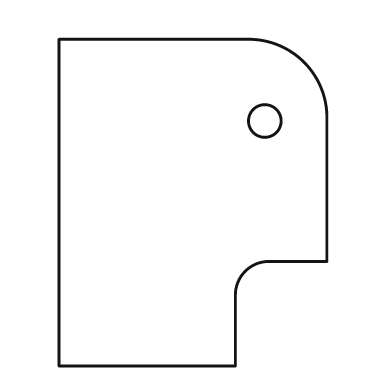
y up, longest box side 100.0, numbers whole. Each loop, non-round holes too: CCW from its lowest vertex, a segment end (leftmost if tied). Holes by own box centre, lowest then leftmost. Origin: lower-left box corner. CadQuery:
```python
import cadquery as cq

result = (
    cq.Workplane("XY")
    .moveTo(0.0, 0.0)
    .lineTo(54.0, 0.0)
    .lineTo(54.0, 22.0)
    .threePointArc((57.0, 29.0), (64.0, 32.0))
    .lineTo(82.0, 32.0)
    .lineTo(82.0, 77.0)
    .threePointArc((75.0, 93.0), (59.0, 100.0))
    .lineTo(0.0, 100.0)
    .close()
    .moveTo(63.0, 75.0)
    .circle(5.0)
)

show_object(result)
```